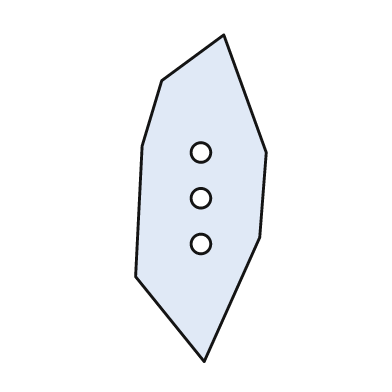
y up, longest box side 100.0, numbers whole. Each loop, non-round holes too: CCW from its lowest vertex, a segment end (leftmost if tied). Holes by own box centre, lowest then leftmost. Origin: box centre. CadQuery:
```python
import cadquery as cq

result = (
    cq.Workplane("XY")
    .moveTo(1.0, -50.0)
    .lineTo(18.0, -12.0)
    .lineTo(20.0, 14.0)
    .lineTo(7.0, 50.0)
    .lineTo(-12.0, 36.0)
    .lineTo(-18.0, 16.0)
    .lineTo(-20.0, -24.0)
    .close()
    .moveTo(0.0, -14.0)
    .circle(3.0)
    .moveTo(0.0, 0.0)
    .circle(3.0)
    .moveTo(0.0, 14.0)
    .circle(3.0)
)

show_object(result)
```